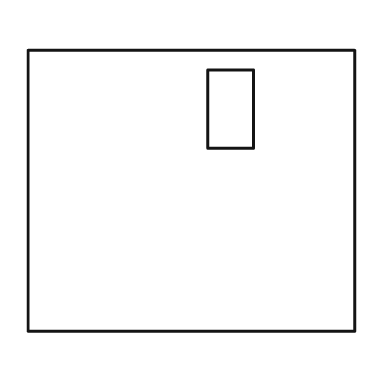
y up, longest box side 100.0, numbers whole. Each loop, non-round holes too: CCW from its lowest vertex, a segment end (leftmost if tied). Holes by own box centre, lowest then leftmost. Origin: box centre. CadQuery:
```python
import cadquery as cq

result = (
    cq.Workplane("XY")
    .moveTo(-50.0, -43.0)
    .lineTo(50.0, -43.0)
    .lineTo(50.0, 43.0)
    .lineTo(-50.0, 43.0)
    .close()
    .moveTo(5.0, 13.0)
    .lineTo(19.0, 13.0)
    .lineTo(19.0, 37.0)
    .lineTo(5.0, 37.0)
    .close()
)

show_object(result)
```